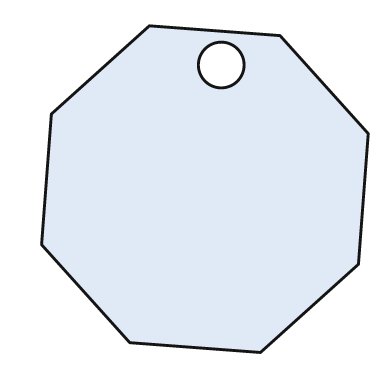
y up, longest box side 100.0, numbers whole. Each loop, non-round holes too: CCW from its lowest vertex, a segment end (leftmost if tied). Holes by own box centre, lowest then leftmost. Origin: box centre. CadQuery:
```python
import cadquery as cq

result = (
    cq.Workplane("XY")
    .moveTo(17.0, -50.0)
    .lineTo(47.0, -23.0)
    .lineTo(50.0, 17.0)
    .lineTo(23.0, 47.0)
    .lineTo(-17.0, 50.0)
    .lineTo(-47.0, 23.0)
    .lineTo(-50.0, -17.0)
    .lineTo(-23.0, -47.0)
    .close()
    .moveTo(5.0, 38.0)
    .circle(7.0)
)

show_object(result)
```